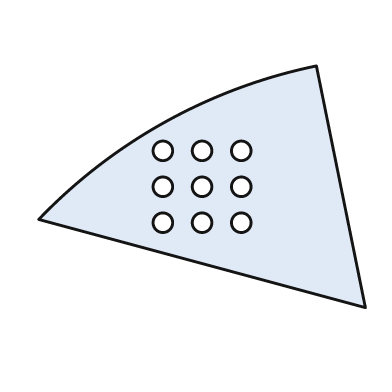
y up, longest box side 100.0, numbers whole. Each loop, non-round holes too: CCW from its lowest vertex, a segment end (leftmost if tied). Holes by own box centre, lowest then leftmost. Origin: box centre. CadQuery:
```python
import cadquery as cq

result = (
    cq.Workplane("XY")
    .moveTo(50.0, -37.0)
    .lineTo(35.0, 37.0)
    .threePointArc((-11.0, 20.0), (-50.0, -10.0))
    .close()
    .moveTo(-12.0, -11.0)
    .circle(3.0)
    .moveTo(0.0, -11.0)
    .circle(3.0)
    .moveTo(12.0, -11.0)
    .circle(3.0)
    .moveTo(-12.0, 0.0)
    .circle(3.0)
    .moveTo(0.0, 0.0)
    .circle(3.0)
    .moveTo(12.0, 0.0)
    .circle(3.0)
    .moveTo(-12.0, 11.0)
    .circle(3.0)
    .moveTo(0.0, 11.0)
    .circle(3.0)
    .moveTo(12.0, 11.0)
    .circle(3.0)
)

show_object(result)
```